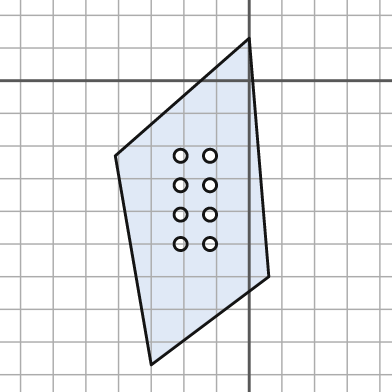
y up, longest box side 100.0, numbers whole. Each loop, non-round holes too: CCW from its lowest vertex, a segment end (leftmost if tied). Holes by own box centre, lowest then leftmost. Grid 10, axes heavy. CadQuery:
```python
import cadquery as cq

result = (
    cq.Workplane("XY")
    .moveTo(-30.0, -87.0)
    .lineTo(6.0, -60.0)
    .lineTo(0.0, 13.0)
    .lineTo(-41.0, -23.0)
    .close()
    .moveTo(-21.0, -50.0)
    .circle(2.0)
    .moveTo(-12.0, -50.0)
    .circle(2.0)
    .moveTo(-21.0, -41.0)
    .circle(2.0)
    .moveTo(-12.0, -41.0)
    .circle(2.0)
    .moveTo(-21.0, -32.0)
    .circle(2.0)
    .moveTo(-12.0, -32.0)
    .circle(2.0)
    .moveTo(-21.0, -23.0)
    .circle(2.0)
    .moveTo(-12.0, -23.0)
    .circle(2.0)
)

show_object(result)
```